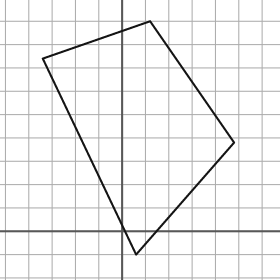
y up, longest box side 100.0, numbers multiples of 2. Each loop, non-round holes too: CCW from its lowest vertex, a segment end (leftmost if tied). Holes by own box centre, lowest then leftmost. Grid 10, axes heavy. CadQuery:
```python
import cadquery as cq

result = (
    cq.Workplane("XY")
    .moveTo(6.0, -10.0)
    .lineTo(48.0, 38.0)
    .lineTo(12.0, 90.0)
    .lineTo(-34.0, 74.0)
    .close()
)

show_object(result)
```